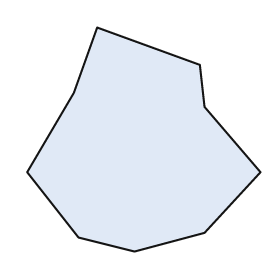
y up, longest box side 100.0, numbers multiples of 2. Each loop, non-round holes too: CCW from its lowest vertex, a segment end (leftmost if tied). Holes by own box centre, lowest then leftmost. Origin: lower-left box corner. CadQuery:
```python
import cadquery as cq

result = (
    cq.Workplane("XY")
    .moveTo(46.0, 0.0)
    .lineTo(76.0, 8.0)
    .lineTo(100.0, 34.0)
    .lineTo(76.0, 62.0)
    .lineTo(74.0, 80.0)
    .lineTo(30.0, 96.0)
    .lineTo(20.0, 68.0)
    .lineTo(0.0, 34.0)
    .lineTo(22.0, 6.0)
    .close()
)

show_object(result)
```